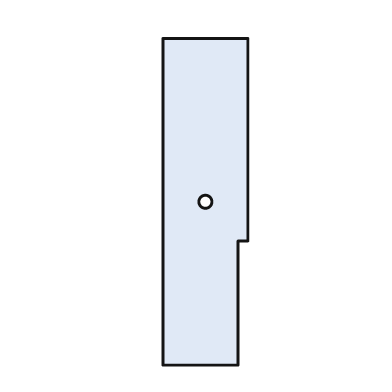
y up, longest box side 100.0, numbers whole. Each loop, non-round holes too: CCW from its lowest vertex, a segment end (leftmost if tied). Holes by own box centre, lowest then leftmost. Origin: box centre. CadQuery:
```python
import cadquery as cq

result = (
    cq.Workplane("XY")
    .moveTo(-13.0, -50.0)
    .lineTo(10.0, -50.0)
    .lineTo(10.0, -12.0)
    .lineTo(13.0, -12.0)
    .lineTo(13.0, 50.0)
    .lineTo(-13.0, 50.0)
    .close()
    .moveTo(0.0, 0.0)
    .circle(2.0)
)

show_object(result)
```